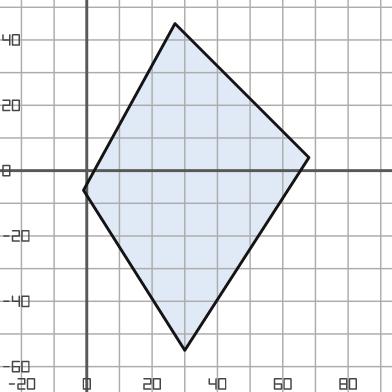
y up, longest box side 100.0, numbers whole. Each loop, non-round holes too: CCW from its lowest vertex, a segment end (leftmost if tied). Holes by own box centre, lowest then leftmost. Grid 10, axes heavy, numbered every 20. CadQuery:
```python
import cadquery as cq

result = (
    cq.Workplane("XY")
    .moveTo(30.0, -55.0)
    .lineTo(68.0, 4.0)
    .lineTo(27.0, 45.0)
    .lineTo(-1.0, -6.0)
    .close()
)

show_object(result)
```